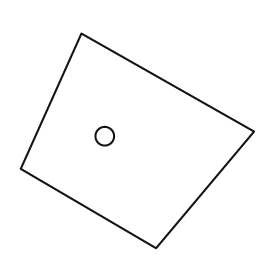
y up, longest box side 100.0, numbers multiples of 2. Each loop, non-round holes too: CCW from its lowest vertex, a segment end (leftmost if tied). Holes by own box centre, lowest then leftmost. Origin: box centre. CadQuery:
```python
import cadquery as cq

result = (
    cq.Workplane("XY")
    .moveTo(8.0, -46.0)
    .lineTo(50.0, 4.0)
    .lineTo(-24.0, 46.0)
    .lineTo(-50.0, -12.0)
    .close()
    .moveTo(-14.0, 2.0)
    .circle(4.0)
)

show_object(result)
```